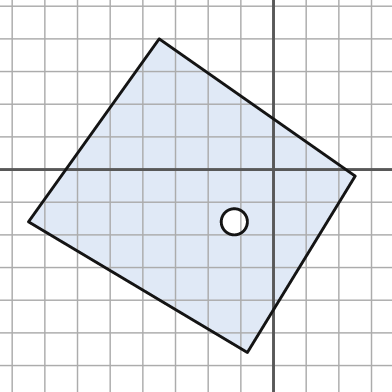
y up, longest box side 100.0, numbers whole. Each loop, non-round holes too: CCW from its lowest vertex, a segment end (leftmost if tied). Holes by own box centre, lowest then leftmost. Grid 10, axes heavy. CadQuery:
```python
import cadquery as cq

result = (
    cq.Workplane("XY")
    .moveTo(-8.0, -56.0)
    .lineTo(25.0, -2.0)
    .lineTo(-35.0, 40.0)
    .lineTo(-75.0, -16.0)
    .close()
    .moveTo(-12.0, -16.0)
    .circle(4.0)
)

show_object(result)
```